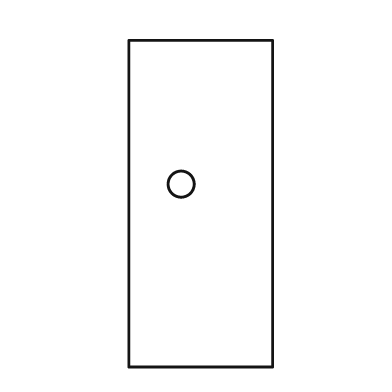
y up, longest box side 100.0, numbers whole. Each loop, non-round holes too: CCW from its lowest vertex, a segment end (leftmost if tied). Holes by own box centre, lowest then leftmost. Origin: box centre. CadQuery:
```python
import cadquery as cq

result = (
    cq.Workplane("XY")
    .moveTo(-22.0, -50.0)
    .lineTo(22.0, -50.0)
    .lineTo(22.0, 50.0)
    .lineTo(-22.0, 50.0)
    .close()
    .moveTo(-6.0, 6.0)
    .circle(4.0)
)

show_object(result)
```